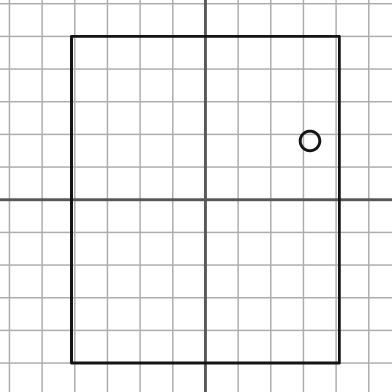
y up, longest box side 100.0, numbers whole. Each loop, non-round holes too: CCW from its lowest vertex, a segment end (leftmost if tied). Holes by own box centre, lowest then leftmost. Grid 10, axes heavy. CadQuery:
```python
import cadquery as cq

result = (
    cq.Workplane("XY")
    .moveTo(-41.0, -50.0)
    .lineTo(41.0, -50.0)
    .lineTo(41.0, 50.0)
    .lineTo(-41.0, 50.0)
    .close()
    .moveTo(32.0, 18.0)
    .circle(3.0)
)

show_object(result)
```